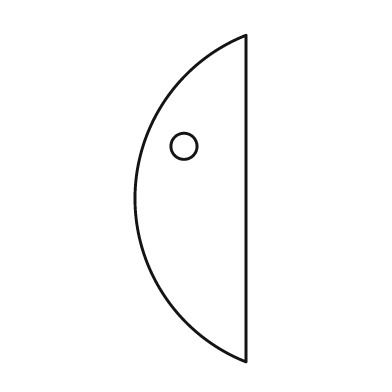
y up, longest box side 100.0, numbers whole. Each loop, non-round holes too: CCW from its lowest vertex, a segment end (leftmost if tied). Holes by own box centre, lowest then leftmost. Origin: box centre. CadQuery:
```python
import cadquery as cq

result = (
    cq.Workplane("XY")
    .moveTo(17.0, -50.0)
    .lineTo(17.0, 50.0)
    .threePointArc((-17.0, 0.0), (17.0, -50.0))
    .close()
    .moveTo(-2.0, 16.0)
    .circle(4.0)
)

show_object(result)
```